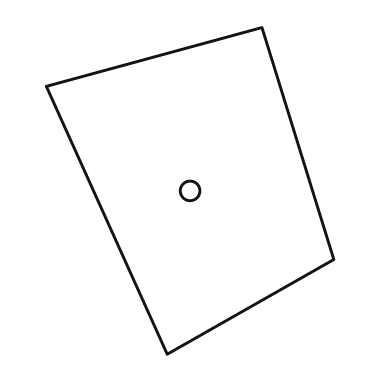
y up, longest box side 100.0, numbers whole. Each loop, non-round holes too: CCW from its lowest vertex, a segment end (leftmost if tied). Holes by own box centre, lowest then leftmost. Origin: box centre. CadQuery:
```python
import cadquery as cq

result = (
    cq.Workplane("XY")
    .moveTo(-7.0, -50.0)
    .lineTo(44.0, -21.0)
    .lineTo(22.0, 50.0)
    .lineTo(-44.0, 32.0)
    .close()
    .moveTo(0.0, 0.0)
    .circle(3.0)
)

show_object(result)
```